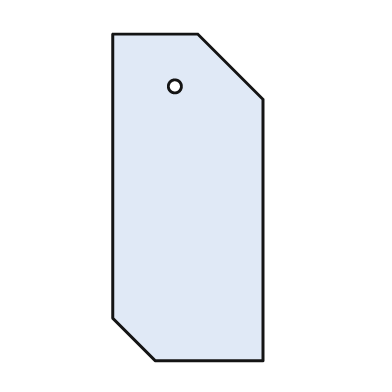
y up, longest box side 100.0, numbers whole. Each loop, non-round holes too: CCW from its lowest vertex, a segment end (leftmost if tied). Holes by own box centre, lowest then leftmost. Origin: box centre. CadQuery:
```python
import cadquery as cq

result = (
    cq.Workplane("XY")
    .moveTo(-10.0, -50.0)
    .lineTo(23.0, -50.0)
    .lineTo(23.0, 30.0)
    .lineTo(3.0, 50.0)
    .lineTo(-23.0, 50.0)
    .lineTo(-23.0, -37.0)
    .close()
    .moveTo(-4.0, 34.0)
    .circle(2.0)
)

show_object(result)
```